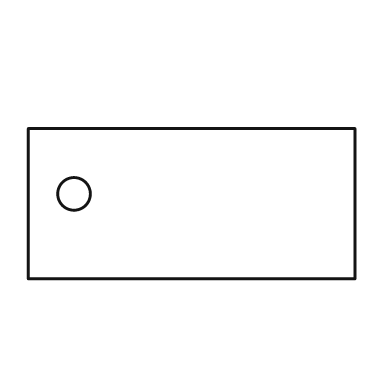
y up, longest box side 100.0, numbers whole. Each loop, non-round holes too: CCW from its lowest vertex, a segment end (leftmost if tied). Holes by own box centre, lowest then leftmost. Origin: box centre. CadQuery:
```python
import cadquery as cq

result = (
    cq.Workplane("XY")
    .moveTo(-50.0, -23.0)
    .lineTo(50.0, -23.0)
    .lineTo(50.0, 23.0)
    .lineTo(-50.0, 23.0)
    .close()
    .moveTo(-36.0, 3.0)
    .circle(5.0)
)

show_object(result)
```